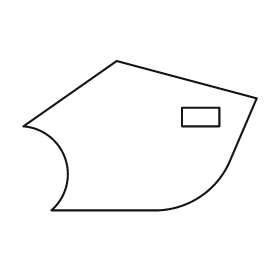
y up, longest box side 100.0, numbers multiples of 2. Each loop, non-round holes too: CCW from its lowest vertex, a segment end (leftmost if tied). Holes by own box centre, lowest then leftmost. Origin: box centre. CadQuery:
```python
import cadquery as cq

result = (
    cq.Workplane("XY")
    .moveTo(-38.0, -32.0)
    .lineTo(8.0, -32.0)
    .threePointArc((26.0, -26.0), (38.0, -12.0))
    .lineTo(50.0, 16.0)
    .lineTo(-10.0, 32.0)
    .lineTo(-50.0, 4.0)
    .threePointArc((-32.0, -10.0), (-38.0, -32.0))
    .close()
    .moveTo(18.0, 4.0)
    .lineTo(34.0, 4.0)
    .lineTo(34.0, 12.0)
    .lineTo(18.0, 12.0)
    .close()
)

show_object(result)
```